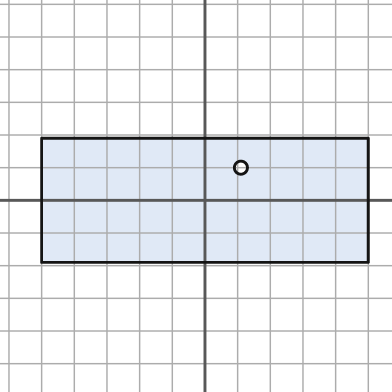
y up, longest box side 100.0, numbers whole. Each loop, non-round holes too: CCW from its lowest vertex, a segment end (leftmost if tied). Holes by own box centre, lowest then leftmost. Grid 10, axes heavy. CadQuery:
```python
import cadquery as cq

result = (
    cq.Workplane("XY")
    .moveTo(-50.0, -19.0)
    .lineTo(50.0, -19.0)
    .lineTo(50.0, 19.0)
    .lineTo(-50.0, 19.0)
    .close()
    .moveTo(11.0, 10.0)
    .circle(2.0)
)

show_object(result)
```